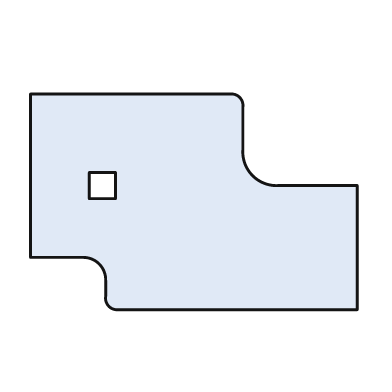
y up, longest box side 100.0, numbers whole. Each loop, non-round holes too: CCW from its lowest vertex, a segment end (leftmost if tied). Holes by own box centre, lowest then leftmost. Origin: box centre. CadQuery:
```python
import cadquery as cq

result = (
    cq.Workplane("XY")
    .moveTo(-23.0, -33.0)
    .lineTo(50.0, -33.0)
    .lineTo(50.0, 5.0)
    .lineTo(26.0, 5.0)
    .threePointArc((18.0, 8.0), (15.0, 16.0))
    .lineTo(15.0, 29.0)
    .threePointArc((14.0, 32.0), (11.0, 33.0))
    .lineTo(-50.0, 33.0)
    .lineTo(-50.0, -17.0)
    .lineTo(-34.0, -17.0)
    .threePointArc((-29.0, -19.0), (-27.0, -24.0))
    .lineTo(-27.0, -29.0)
    .threePointArc((-26.0, -32.0), (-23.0, -33.0))
    .close()
    .moveTo(-32.0, 1.0)
    .lineTo(-24.0, 1.0)
    .lineTo(-24.0, 9.0)
    .lineTo(-32.0, 9.0)
    .close()
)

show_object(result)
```